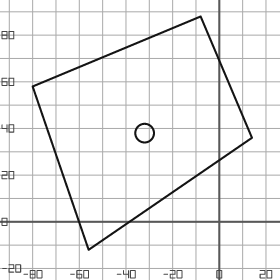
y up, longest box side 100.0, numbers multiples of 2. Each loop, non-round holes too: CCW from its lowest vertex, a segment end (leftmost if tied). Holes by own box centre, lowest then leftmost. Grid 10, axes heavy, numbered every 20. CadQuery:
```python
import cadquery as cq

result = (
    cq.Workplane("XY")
    .moveTo(-56.0, -12.0)
    .lineTo(14.0, 36.0)
    .lineTo(-8.0, 88.0)
    .lineTo(-80.0, 58.0)
    .close()
    .moveTo(-32.0, 38.0)
    .circle(4.0)
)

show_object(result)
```